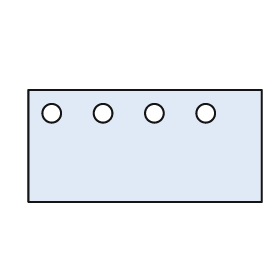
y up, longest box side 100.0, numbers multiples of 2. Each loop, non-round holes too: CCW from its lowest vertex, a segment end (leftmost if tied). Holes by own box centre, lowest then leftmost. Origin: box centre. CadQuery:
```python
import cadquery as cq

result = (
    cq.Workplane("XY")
    .moveTo(-50.0, -24.0)
    .lineTo(50.0, -24.0)
    .lineTo(50.0, 24.0)
    .lineTo(-50.0, 24.0)
    .close()
    .moveTo(-40.0, 14.0)
    .circle(4.0)
    .moveTo(-18.0, 14.0)
    .circle(4.0)
    .moveTo(4.0, 14.0)
    .circle(4.0)
    .moveTo(26.0, 14.0)
    .circle(4.0)
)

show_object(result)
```